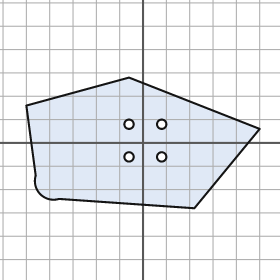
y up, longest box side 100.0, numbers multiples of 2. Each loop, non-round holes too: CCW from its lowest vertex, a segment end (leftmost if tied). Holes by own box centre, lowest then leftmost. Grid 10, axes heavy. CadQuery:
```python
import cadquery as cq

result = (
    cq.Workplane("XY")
    .moveTo(22.0, -28.0)
    .lineTo(50.0, 6.0)
    .lineTo(-6.0, 28.0)
    .lineTo(-50.0, 16.0)
    .lineTo(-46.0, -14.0)
    .threePointArc((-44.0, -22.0), (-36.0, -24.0))
    .close()
    .moveTo(-6.0, -6.0)
    .circle(2.0)
    .moveTo(8.0, -6.0)
    .circle(2.0)
    .moveTo(-6.0, 8.0)
    .circle(2.0)
    .moveTo(8.0, 8.0)
    .circle(2.0)
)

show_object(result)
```